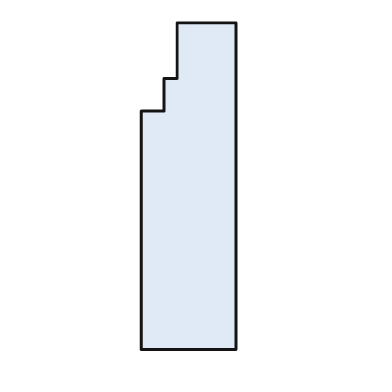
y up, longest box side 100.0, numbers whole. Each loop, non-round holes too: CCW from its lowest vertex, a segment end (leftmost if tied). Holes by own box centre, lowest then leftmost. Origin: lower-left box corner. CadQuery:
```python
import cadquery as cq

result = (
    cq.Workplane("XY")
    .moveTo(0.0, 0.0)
    .lineTo(29.0, 0.0)
    .lineTo(29.0, 100.0)
    .lineTo(11.0, 100.0)
    .lineTo(11.0, 83.0)
    .lineTo(7.0, 83.0)
    .lineTo(7.0, 73.0)
    .lineTo(0.0, 73.0)
    .close()
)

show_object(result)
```